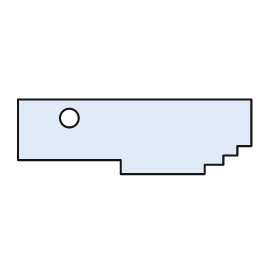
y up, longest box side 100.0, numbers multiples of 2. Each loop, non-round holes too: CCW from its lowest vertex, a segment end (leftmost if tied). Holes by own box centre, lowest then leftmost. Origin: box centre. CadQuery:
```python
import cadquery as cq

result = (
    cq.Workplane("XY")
    .moveTo(-6.0, -16.0)
    .lineTo(30.0, -16.0)
    .lineTo(30.0, -12.0)
    .lineTo(38.0, -12.0)
    .lineTo(38.0, -8.0)
    .lineTo(44.0, -8.0)
    .lineTo(44.0, -4.0)
    .lineTo(50.0, -4.0)
    .lineTo(50.0, 16.0)
    .lineTo(-50.0, 16.0)
    .lineTo(-50.0, -10.0)
    .lineTo(-6.0, -10.0)
    .close()
    .moveTo(-28.0, 8.0)
    .circle(4.0)
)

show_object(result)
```